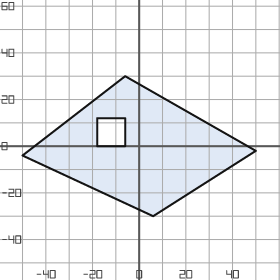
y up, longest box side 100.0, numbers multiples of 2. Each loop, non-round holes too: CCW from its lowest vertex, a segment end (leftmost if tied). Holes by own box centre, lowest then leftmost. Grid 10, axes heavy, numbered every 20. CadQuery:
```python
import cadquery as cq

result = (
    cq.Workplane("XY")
    .moveTo(6.0, -30.0)
    .lineTo(50.0, -2.0)
    .lineTo(-6.0, 30.0)
    .lineTo(-50.0, -4.0)
    .close()
    .moveTo(-18.0, 0.0)
    .lineTo(-6.0, 0.0)
    .lineTo(-6.0, 12.0)
    .lineTo(-18.0, 12.0)
    .close()
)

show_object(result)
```